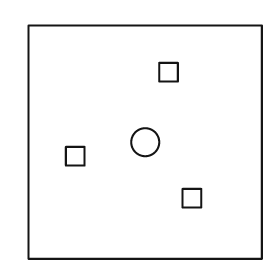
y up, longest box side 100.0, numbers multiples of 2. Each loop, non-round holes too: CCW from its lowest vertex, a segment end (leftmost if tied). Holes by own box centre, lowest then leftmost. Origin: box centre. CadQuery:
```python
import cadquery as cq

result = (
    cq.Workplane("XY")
    .moveTo(-50.0, -50.0)
    .lineTo(50.0, -50.0)
    .lineTo(50.0, 50.0)
    .lineTo(-50.0, 50.0)
    .close()
    .moveTo(16.0, -28.0)
    .lineTo(24.0, -28.0)
    .lineTo(24.0, -20.0)
    .lineTo(16.0, -20.0)
    .close()
    .moveTo(-34.0, -10.0)
    .lineTo(-26.0, -10.0)
    .lineTo(-26.0, -2.0)
    .lineTo(-34.0, -2.0)
    .close()
    .moveTo(0.0, 0.0)
    .circle(6.0)
    .moveTo(6.0, 26.0)
    .lineTo(14.0, 26.0)
    .lineTo(14.0, 34.0)
    .lineTo(6.0, 34.0)
    .close()
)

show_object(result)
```